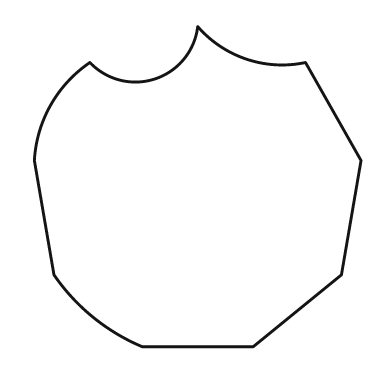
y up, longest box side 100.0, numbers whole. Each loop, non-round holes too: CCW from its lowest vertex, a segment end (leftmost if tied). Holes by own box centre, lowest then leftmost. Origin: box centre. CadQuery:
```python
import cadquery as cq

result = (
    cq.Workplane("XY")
    .moveTo(-17.0, -49.0)
    .lineTo(17.0, -49.0)
    .lineTo(44.0, -27.0)
    .lineTo(50.0, 8.0)
    .lineTo(33.0, 38.0)
    .threePointArc((15.0, 39.0), (0.0, 49.0))
    .threePointArc((-13.0, 33.0), (-33.0, 38.0))
    .threePointArc((-45.0, 25.0), (-50.0, 8.0))
    .lineTo(-44.0, -27.0)
    .threePointArc((-32.0, -40.0), (-17.0, -49.0))
    .close()
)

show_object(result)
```